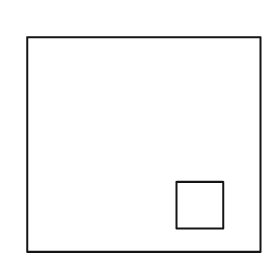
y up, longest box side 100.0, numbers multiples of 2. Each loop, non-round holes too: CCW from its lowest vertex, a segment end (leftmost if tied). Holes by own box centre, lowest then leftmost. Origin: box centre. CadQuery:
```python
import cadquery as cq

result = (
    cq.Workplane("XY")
    .moveTo(-50.0, -46.0)
    .lineTo(50.0, -46.0)
    .lineTo(50.0, 46.0)
    .lineTo(-50.0, 46.0)
    .close()
    .moveTo(14.0, -36.0)
    .lineTo(34.0, -36.0)
    .lineTo(34.0, -16.0)
    .lineTo(14.0, -16.0)
    .close()
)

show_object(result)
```